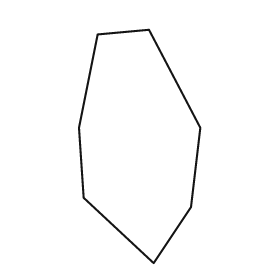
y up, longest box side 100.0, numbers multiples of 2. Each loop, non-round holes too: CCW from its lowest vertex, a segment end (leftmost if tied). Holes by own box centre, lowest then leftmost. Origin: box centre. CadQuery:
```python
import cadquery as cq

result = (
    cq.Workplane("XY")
    .moveTo(6.0, -50.0)
    .lineTo(22.0, -26.0)
    .lineTo(26.0, 8.0)
    .lineTo(4.0, 50.0)
    .lineTo(-18.0, 48.0)
    .lineTo(-26.0, 8.0)
    .lineTo(-24.0, -22.0)
    .close()
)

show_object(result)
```